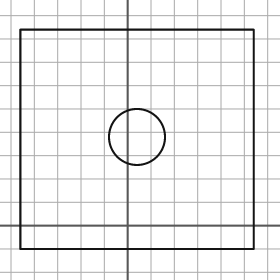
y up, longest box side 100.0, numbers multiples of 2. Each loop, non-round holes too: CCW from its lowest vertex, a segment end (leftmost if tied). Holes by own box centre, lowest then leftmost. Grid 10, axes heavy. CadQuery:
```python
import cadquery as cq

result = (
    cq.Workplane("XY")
    .moveTo(-46.0, -10.0)
    .lineTo(54.0, -10.0)
    .lineTo(54.0, 84.0)
    .lineTo(-46.0, 84.0)
    .close()
    .moveTo(4.0, 38.0)
    .circle(12.0)
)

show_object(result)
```